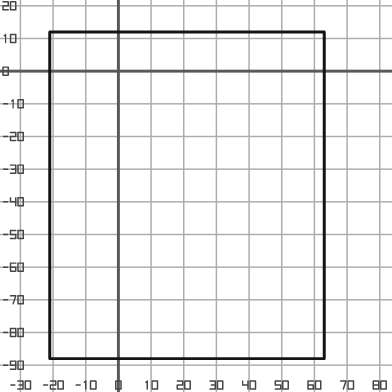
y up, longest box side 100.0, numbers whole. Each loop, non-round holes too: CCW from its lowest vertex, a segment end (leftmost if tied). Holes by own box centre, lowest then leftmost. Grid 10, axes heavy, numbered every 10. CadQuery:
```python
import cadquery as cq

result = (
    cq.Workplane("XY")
    .moveTo(-21.0, -88.0)
    .lineTo(63.0, -88.0)
    .lineTo(63.0, 12.0)
    .lineTo(-21.0, 12.0)
    .close()
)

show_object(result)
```